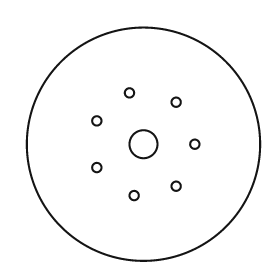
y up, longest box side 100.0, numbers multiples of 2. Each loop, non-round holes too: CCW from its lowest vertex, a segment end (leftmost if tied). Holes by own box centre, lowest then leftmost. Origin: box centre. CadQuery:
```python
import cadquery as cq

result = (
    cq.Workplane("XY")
    .moveTo(0.0, 0.0)
    .circle(50.0)
    .moveTo(-4.0, -22.0)
    .circle(2.0)
    .moveTo(14.0, -18.0)
    .circle(2.0)
    .moveTo(-20.0, -10.0)
    .circle(2.0)
    .moveTo(0.0, 0.0)
    .circle(6.0)
    .moveTo(22.0, 0.0)
    .circle(2.0)
    .moveTo(-20.0, 10.0)
    .circle(2.0)
    .moveTo(14.0, 18.0)
    .circle(2.0)
    .moveTo(-6.0, 22.0)
    .circle(2.0)
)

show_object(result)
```